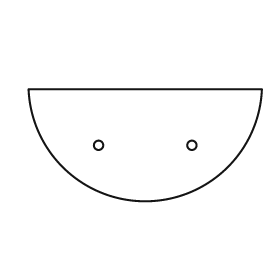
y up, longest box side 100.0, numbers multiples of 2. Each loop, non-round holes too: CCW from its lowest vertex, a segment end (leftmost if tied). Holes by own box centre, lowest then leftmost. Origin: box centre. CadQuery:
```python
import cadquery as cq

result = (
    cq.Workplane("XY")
    .moveTo(-50.0, 24.0)
    .threePointArc((0.0, -24.0), (50.0, 24.0))
    .close()
    .moveTo(-20.0, 0.0)
    .circle(2.0)
    .moveTo(20.0, 0.0)
    .circle(2.0)
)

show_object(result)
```